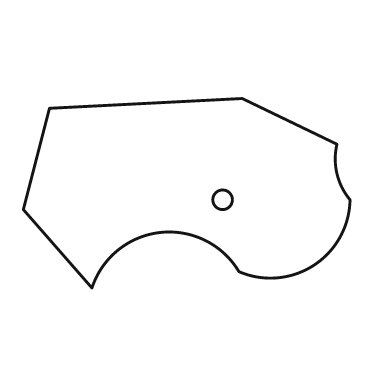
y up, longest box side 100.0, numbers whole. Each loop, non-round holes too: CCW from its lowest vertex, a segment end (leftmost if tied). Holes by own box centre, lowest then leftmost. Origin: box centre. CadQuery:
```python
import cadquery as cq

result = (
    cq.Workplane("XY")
    .moveTo(-29.0, -29.0)
    .threePointArc((-8.0, -12.0), (16.0, -24.0))
    .threePointArc((39.0, -22.0), (50.0, -2.0))
    .threePointArc((46.0, 6.0), (46.0, 15.0))
    .lineTo(17.0, 29.0)
    .lineTo(-42.0, 26.0)
    .lineTo(-50.0, -5.0)
    .close()
    .moveTo(11.0, -2.0)
    .circle(3.0)
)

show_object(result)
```